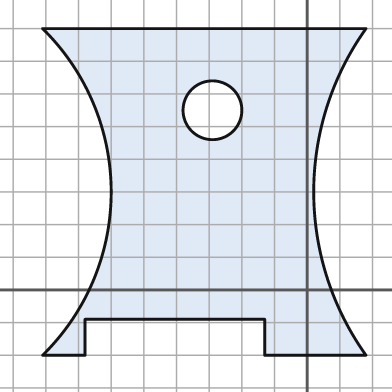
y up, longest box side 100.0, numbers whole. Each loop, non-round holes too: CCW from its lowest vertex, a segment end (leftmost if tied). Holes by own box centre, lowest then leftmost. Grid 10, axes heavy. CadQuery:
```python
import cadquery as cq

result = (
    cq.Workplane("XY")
    .moveTo(-81.0, -20.0)
    .lineTo(-68.0, -20.0)
    .lineTo(-68.0, -9.0)
    .lineTo(-13.0, -9.0)
    .lineTo(-13.0, -20.0)
    .lineTo(18.0, -20.0)
    .threePointArc((2.0, 30.0), (18.0, 80.0))
    .lineTo(-81.0, 80.0)
    .threePointArc((-60.0, 30.0), (-81.0, -20.0))
    .close()
    .moveTo(-29.0, 55.0)
    .circle(9.0)
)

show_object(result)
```